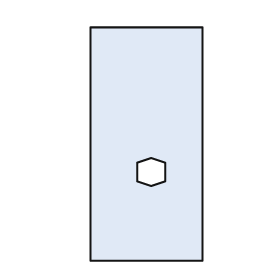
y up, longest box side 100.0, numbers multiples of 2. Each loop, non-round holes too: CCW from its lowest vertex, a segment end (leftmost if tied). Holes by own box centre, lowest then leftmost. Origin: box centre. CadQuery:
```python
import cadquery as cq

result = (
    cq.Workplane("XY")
    .moveTo(-24.0, -50.0)
    .lineTo(24.0, -50.0)
    .lineTo(24.0, 50.0)
    .lineTo(-24.0, 50.0)
    .close()
    .moveTo(2.0, -18.0)
    .lineTo(8.0, -16.0)
    .lineTo(8.0, -8.0)
    .lineTo(2.0, -6.0)
    .lineTo(-4.0, -8.0)
    .lineTo(-4.0, -16.0)
    .close()
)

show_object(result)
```